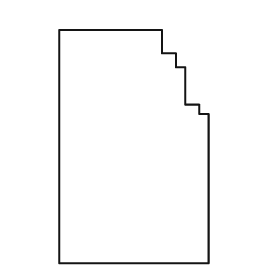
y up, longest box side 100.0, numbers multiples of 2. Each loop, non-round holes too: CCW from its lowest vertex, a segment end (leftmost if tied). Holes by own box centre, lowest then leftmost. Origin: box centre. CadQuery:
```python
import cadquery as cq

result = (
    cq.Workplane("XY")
    .moveTo(-32.0, -50.0)
    .lineTo(32.0, -50.0)
    .lineTo(32.0, 14.0)
    .lineTo(28.0, 14.0)
    .lineTo(28.0, 18.0)
    .lineTo(22.0, 18.0)
    .lineTo(22.0, 34.0)
    .lineTo(18.0, 34.0)
    .lineTo(18.0, 40.0)
    .lineTo(12.0, 40.0)
    .lineTo(12.0, 50.0)
    .lineTo(-32.0, 50.0)
    .close()
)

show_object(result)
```